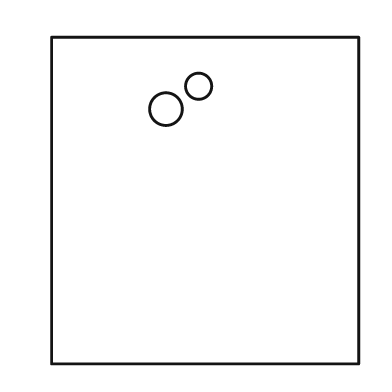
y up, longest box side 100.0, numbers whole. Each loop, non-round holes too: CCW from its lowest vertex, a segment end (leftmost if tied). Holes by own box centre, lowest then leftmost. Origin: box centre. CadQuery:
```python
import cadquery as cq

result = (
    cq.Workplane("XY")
    .moveTo(-47.0, -50.0)
    .lineTo(47.0, -50.0)
    .lineTo(47.0, 50.0)
    .lineTo(-47.0, 50.0)
    .close()
    .moveTo(-12.0, 28.0)
    .circle(5.0)
    .moveTo(-2.0, 35.0)
    .circle(4.0)
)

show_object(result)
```